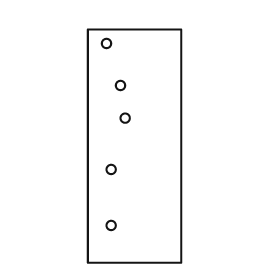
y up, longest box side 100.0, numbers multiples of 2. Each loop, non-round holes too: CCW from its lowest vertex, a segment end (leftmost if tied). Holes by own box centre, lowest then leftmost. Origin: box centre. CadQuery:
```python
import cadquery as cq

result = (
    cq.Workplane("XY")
    .moveTo(-20.0, -50.0)
    .lineTo(20.0, -50.0)
    .lineTo(20.0, 50.0)
    .lineTo(-20.0, 50.0)
    .close()
    .moveTo(-10.0, -34.0)
    .circle(2.0)
    .moveTo(-10.0, -10.0)
    .circle(2.0)
    .moveTo(-4.0, 12.0)
    .circle(2.0)
    .moveTo(-6.0, 26.0)
    .circle(2.0)
    .moveTo(-12.0, 44.0)
    .circle(2.0)
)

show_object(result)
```